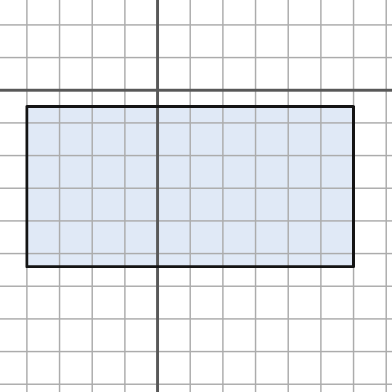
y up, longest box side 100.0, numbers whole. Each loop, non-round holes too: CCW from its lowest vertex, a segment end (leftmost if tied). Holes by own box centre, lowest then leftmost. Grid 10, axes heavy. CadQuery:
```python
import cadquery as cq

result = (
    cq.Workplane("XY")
    .moveTo(-40.0, -54.0)
    .lineTo(60.0, -54.0)
    .lineTo(60.0, -5.0)
    .lineTo(-40.0, -5.0)
    .close()
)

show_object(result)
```